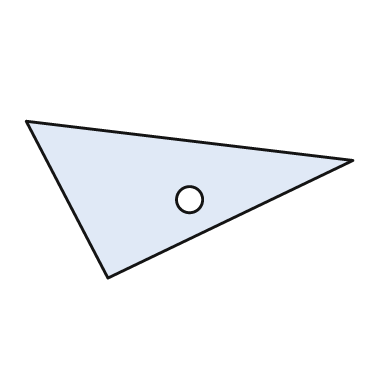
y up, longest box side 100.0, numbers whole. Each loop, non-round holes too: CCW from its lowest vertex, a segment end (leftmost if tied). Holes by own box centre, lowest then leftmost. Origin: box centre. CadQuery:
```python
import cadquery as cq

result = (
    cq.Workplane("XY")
    .moveTo(-25.0, -24.0)
    .lineTo(50.0, 12.0)
    .lineTo(-50.0, 24.0)
    .close()
    .moveTo(0.0, 0.0)
    .circle(4.0)
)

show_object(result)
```